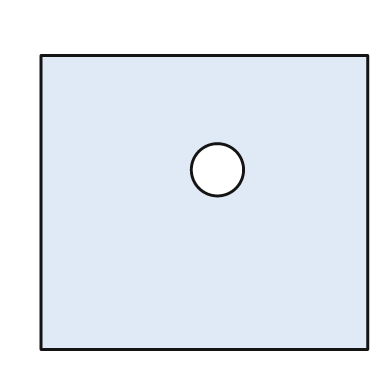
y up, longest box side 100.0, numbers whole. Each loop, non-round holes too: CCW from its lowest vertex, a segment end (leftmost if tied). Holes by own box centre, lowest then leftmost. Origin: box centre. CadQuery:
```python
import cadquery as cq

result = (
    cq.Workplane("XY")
    .moveTo(-50.0, -45.0)
    .lineTo(50.0, -45.0)
    .lineTo(50.0, 45.0)
    .lineTo(-50.0, 45.0)
    .close()
    .moveTo(4.0, 10.0)
    .circle(8.0)
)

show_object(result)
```